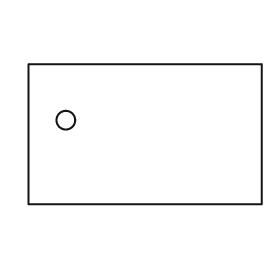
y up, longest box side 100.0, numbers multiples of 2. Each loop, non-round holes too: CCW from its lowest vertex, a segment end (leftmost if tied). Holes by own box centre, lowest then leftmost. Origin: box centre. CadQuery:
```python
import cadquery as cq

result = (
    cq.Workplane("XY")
    .moveTo(-50.0, -30.0)
    .lineTo(50.0, -30.0)
    .lineTo(50.0, 30.0)
    .lineTo(-50.0, 30.0)
    .close()
    .moveTo(-34.0, 6.0)
    .circle(4.0)
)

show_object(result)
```